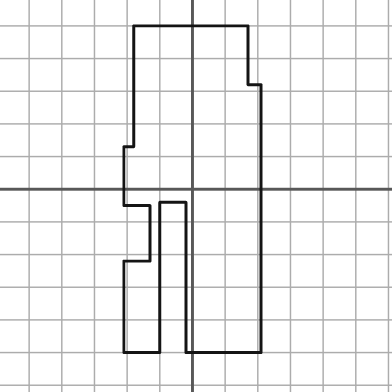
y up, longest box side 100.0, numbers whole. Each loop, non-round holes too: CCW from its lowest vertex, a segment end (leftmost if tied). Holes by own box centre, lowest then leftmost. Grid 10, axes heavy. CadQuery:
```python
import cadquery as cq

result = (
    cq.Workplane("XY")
    .moveTo(-21.0, -50.0)
    .lineTo(-10.0, -50.0)
    .lineTo(-10.0, -4.0)
    .lineTo(-2.0, -4.0)
    .lineTo(-2.0, -50.0)
    .lineTo(21.0, -50.0)
    .lineTo(21.0, 32.0)
    .lineTo(17.0, 32.0)
    .lineTo(17.0, 50.0)
    .lineTo(-18.0, 50.0)
    .lineTo(-18.0, 13.0)
    .lineTo(-21.0, 13.0)
    .lineTo(-21.0, -5.0)
    .lineTo(-13.0, -5.0)
    .lineTo(-13.0, -22.0)
    .lineTo(-21.0, -22.0)
    .close()
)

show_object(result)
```